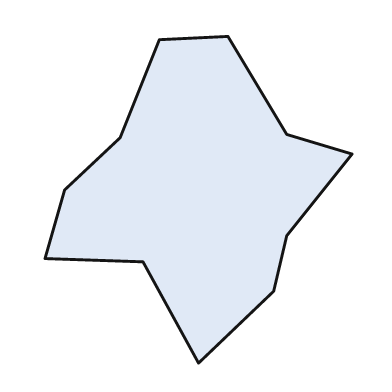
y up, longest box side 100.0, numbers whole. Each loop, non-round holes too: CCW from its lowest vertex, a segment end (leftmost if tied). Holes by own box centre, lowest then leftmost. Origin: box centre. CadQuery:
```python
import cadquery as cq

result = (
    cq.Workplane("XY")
    .moveTo(0.0, -50.0)
    .lineTo(23.0, -28.0)
    .lineTo(27.0, -11.0)
    .lineTo(47.0, 14.0)
    .lineTo(27.0, 20.0)
    .lineTo(9.0, 50.0)
    .lineTo(-12.0, 49.0)
    .lineTo(-24.0, 19.0)
    .lineTo(-41.0, 3.0)
    .lineTo(-47.0, -18.0)
    .lineTo(-17.0, -19.0)
    .close()
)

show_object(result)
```